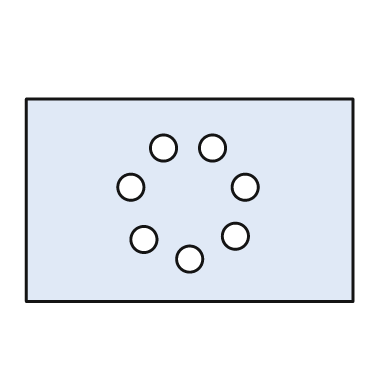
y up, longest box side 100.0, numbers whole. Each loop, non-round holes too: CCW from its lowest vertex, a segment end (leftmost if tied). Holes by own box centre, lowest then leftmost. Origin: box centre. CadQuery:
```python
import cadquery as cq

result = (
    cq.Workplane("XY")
    .moveTo(-50.0, -31.0)
    .lineTo(50.0, -31.0)
    .lineTo(50.0, 31.0)
    .lineTo(-50.0, 31.0)
    .close()
    .moveTo(0.0, -18.0)
    .circle(4.0)
    .moveTo(-14.0, -12.0)
    .circle(4.0)
    .moveTo(14.0, -11.0)
    .circle(4.0)
    .moveTo(-18.0, 4.0)
    .circle(4.0)
    .moveTo(17.0, 4.0)
    .circle(4.0)
    .moveTo(-8.0, 16.0)
    .circle(4.0)
    .moveTo(7.0, 16.0)
    .circle(4.0)
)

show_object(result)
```